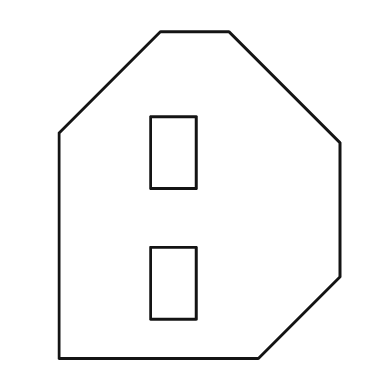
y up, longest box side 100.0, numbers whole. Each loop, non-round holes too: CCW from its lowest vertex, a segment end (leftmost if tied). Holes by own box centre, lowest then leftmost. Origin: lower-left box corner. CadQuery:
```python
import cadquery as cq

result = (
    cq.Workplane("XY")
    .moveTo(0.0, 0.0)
    .lineTo(61.0, 0.0)
    .lineTo(86.0, 25.0)
    .lineTo(86.0, 66.0)
    .lineTo(52.0, 100.0)
    .lineTo(31.0, 100.0)
    .lineTo(0.0, 69.0)
    .close()
    .moveTo(28.0, 12.0)
    .lineTo(42.0, 12.0)
    .lineTo(42.0, 34.0)
    .lineTo(28.0, 34.0)
    .close()
    .moveTo(28.0, 52.0)
    .lineTo(42.0, 52.0)
    .lineTo(42.0, 74.0)
    .lineTo(28.0, 74.0)
    .close()
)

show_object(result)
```